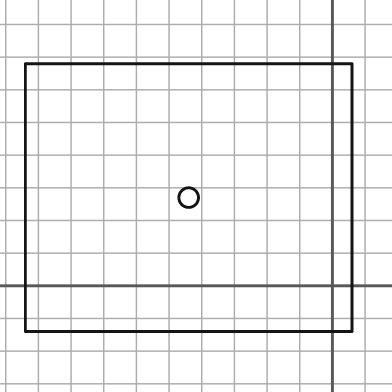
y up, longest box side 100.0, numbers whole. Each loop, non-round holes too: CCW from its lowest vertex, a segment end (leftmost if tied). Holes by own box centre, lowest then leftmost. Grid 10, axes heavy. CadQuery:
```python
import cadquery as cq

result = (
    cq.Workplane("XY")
    .moveTo(-94.0, -14.0)
    .lineTo(6.0, -14.0)
    .lineTo(6.0, 68.0)
    .lineTo(-94.0, 68.0)
    .close()
    .moveTo(-44.0, 27.0)
    .circle(3.0)
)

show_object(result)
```